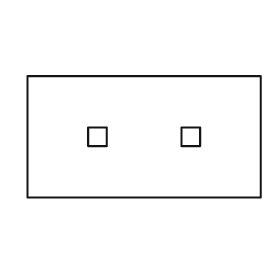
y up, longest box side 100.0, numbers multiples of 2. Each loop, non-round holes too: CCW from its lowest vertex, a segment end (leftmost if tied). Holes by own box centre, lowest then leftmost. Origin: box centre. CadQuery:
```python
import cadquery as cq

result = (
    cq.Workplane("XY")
    .moveTo(-50.0, -26.0)
    .lineTo(50.0, -26.0)
    .lineTo(50.0, 26.0)
    .lineTo(-50.0, 26.0)
    .close()
    .moveTo(-24.0, -4.0)
    .lineTo(-16.0, -4.0)
    .lineTo(-16.0, 4.0)
    .lineTo(-24.0, 4.0)
    .close()
    .moveTo(16.0, -4.0)
    .lineTo(24.0, -4.0)
    .lineTo(24.0, 4.0)
    .lineTo(16.0, 4.0)
    .close()
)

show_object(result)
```